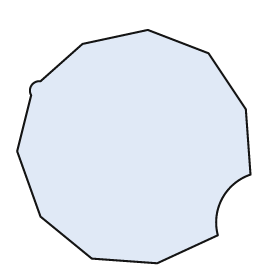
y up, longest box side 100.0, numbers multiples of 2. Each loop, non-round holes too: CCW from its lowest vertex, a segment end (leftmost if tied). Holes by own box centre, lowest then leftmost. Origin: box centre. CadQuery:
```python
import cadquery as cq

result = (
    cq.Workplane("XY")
    .moveTo(10.0, -50.0)
    .lineTo(36.0, -38.0)
    .threePointArc((38.0, -22.0), (50.0, -12.0))
    .lineTo(48.0, 16.0)
    .lineTo(32.0, 40.0)
    .lineTo(6.0, 50.0)
    .lineTo(-22.0, 44.0)
    .lineTo(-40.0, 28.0)
    .threePointArc((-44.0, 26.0), (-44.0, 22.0))
    .lineTo(-50.0, -2.0)
    .lineTo(-40.0, -30.0)
    .lineTo(-18.0, -48.0)
    .close()
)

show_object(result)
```